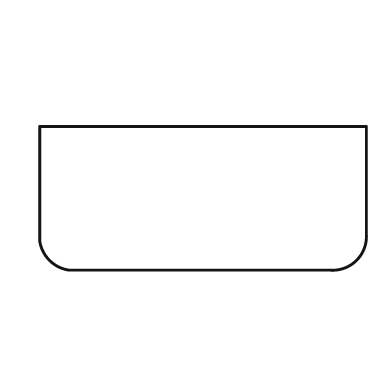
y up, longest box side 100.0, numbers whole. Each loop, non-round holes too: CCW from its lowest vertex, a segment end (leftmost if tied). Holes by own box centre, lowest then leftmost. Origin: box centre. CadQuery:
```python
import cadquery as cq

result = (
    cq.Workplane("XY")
    .moveTo(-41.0, -22.0)
    .lineTo(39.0, -22.0)
    .threePointArc((47.0, -19.0), (50.0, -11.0))
    .lineTo(50.0, 22.0)
    .lineTo(-50.0, 22.0)
    .lineTo(-50.0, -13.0)
    .threePointArc((-47.0, -19.0), (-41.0, -22.0))
    .close()
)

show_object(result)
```